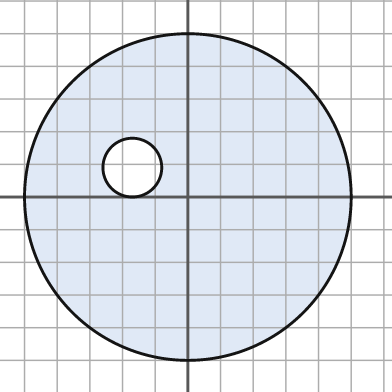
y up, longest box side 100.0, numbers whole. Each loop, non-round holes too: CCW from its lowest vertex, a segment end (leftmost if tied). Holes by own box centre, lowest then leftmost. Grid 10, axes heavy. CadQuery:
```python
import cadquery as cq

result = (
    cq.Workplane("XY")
    .moveTo(0.0, 0.0)
    .circle(50.0)
    .moveTo(-17.0, 9.0)
    .circle(9.0)
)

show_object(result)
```